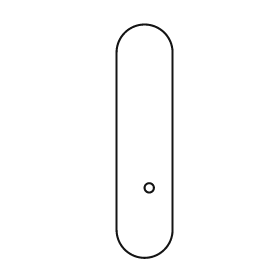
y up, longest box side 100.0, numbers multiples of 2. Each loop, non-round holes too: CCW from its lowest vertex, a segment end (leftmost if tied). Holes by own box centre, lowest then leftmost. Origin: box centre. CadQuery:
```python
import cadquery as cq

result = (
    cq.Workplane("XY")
    .moveTo(-12.0, -38.0)
    .threePointArc((0.0, -50.0), (12.0, -38.0))
    .lineTo(12.0, 38.0)
    .threePointArc((0.0, 50.0), (-12.0, 38.0))
    .close()
    .moveTo(2.0, -20.0)
    .circle(2.0)
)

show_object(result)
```